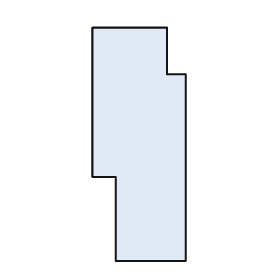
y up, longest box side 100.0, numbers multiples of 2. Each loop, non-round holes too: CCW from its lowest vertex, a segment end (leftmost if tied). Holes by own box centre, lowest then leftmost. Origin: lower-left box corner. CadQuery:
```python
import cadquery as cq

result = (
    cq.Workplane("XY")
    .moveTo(10.0, 0.0)
    .lineTo(40.0, 0.0)
    .lineTo(40.0, 80.0)
    .lineTo(32.0, 80.0)
    .lineTo(32.0, 100.0)
    .lineTo(0.0, 100.0)
    .lineTo(0.0, 36.0)
    .lineTo(10.0, 36.0)
    .close()
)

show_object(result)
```